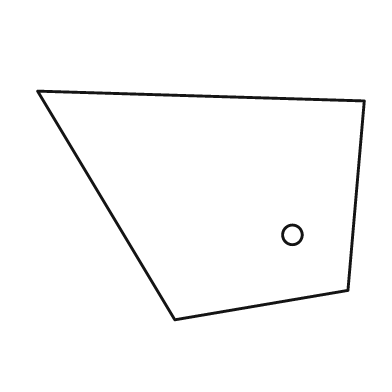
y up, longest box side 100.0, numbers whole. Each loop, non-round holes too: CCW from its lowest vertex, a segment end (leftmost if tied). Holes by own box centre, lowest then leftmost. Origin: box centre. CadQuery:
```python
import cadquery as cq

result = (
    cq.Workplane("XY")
    .moveTo(-8.0, -35.0)
    .lineTo(45.0, -26.0)
    .lineTo(50.0, 32.0)
    .lineTo(-50.0, 35.0)
    .close()
    .moveTo(28.0, -9.0)
    .circle(3.0)
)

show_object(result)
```